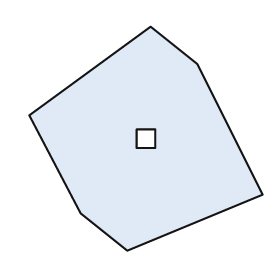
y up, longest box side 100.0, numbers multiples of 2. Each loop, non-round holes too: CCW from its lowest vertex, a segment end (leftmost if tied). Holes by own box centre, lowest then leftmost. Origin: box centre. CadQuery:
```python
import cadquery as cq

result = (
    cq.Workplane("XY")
    .moveTo(-8.0, -48.0)
    .lineTo(50.0, -24.0)
    .lineTo(22.0, 32.0)
    .lineTo(2.0, 48.0)
    .lineTo(-50.0, 10.0)
    .lineTo(-28.0, -32.0)
    .close()
    .moveTo(-4.0, -4.0)
    .lineTo(4.0, -4.0)
    .lineTo(4.0, 4.0)
    .lineTo(-4.0, 4.0)
    .close()
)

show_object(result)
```